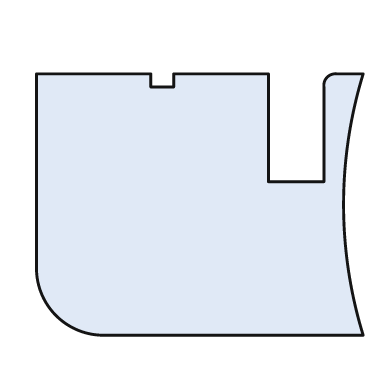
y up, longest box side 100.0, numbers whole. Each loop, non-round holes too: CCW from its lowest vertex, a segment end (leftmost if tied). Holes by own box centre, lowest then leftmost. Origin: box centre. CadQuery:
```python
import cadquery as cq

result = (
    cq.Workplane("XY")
    .moveTo(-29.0, -40.0)
    .lineTo(50.0, -40.0)
    .threePointArc((44.0, 0.0), (50.0, 40.0))
    .lineTo(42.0, 40.0)
    .threePointArc((39.0, 39.0), (38.0, 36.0))
    .lineTo(38.0, 7.0)
    .lineTo(21.0, 7.0)
    .lineTo(21.0, 40.0)
    .lineTo(-8.0, 40.0)
    .lineTo(-8.0, 36.0)
    .lineTo(-15.0, 36.0)
    .lineTo(-15.0, 40.0)
    .lineTo(-50.0, 40.0)
    .lineTo(-50.0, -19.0)
    .threePointArc((-44.0, -34.0), (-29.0, -40.0))
    .close()
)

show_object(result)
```